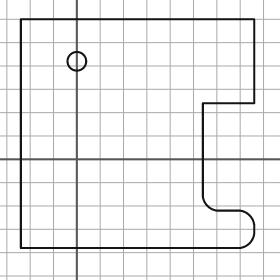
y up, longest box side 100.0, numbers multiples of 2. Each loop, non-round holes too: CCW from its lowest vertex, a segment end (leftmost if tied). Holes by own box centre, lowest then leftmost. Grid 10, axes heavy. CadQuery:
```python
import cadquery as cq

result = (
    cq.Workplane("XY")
    .moveTo(-24.0, -38.0)
    .lineTo(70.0, -38.0)
    .threePointArc((74.0, -36.0), (76.0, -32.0))
    .lineTo(76.0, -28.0)
    .threePointArc((74.0, -24.0), (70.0, -22.0))
    .lineTo(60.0, -22.0)
    .threePointArc((56.0, -20.0), (54.0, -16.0))
    .lineTo(54.0, 24.0)
    .lineTo(76.0, 24.0)
    .lineTo(76.0, 60.0)
    .lineTo(-24.0, 60.0)
    .close()
    .moveTo(0.0, 42.0)
    .circle(4.0)
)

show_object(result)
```